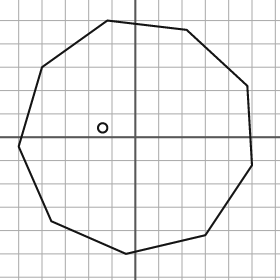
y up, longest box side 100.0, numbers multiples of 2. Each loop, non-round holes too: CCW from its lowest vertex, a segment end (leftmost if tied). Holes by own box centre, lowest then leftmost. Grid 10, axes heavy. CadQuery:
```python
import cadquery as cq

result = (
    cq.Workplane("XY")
    .moveTo(-4.0, -50.0)
    .lineTo(30.0, -42.0)
    .lineTo(50.0, -12.0)
    .lineTo(48.0, 22.0)
    .lineTo(22.0, 46.0)
    .lineTo(-12.0, 50.0)
    .lineTo(-40.0, 30.0)
    .lineTo(-50.0, -4.0)
    .lineTo(-36.0, -36.0)
    .close()
    .moveTo(-14.0, 4.0)
    .circle(2.0)
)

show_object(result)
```